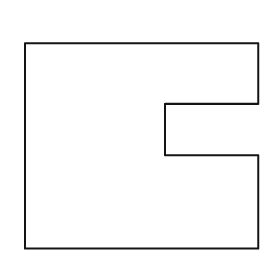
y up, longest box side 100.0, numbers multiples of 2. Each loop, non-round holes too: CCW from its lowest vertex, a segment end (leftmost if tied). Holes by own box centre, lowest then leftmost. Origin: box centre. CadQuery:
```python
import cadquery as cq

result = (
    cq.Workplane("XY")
    .moveTo(-50.0, -44.0)
    .lineTo(50.0, -44.0)
    .lineTo(50.0, -4.0)
    .lineTo(10.0, -4.0)
    .lineTo(10.0, 18.0)
    .lineTo(50.0, 18.0)
    .lineTo(50.0, 44.0)
    .lineTo(-50.0, 44.0)
    .close()
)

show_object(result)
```